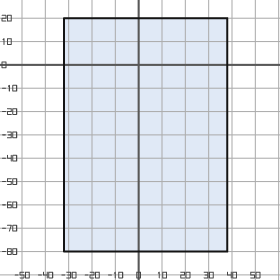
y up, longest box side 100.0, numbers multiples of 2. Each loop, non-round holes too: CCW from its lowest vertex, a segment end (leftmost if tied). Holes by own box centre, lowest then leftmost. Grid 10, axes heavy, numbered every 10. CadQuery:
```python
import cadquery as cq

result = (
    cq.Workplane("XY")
    .moveTo(-32.0, -80.0)
    .lineTo(38.0, -80.0)
    .lineTo(38.0, 20.0)
    .lineTo(-32.0, 20.0)
    .close()
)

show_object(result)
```